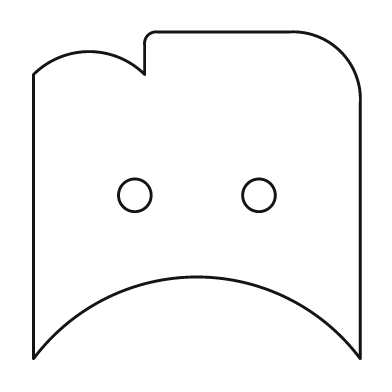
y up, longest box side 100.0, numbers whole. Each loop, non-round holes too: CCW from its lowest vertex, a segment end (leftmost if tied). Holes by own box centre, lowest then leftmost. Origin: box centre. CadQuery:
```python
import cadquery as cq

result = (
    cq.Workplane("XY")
    .moveTo(-50.0, -50.0)
    .threePointArc((0.0, -25.0), (50.0, -50.0))
    .lineTo(50.0, 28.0)
    .threePointArc((44.0, 44.0), (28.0, 50.0))
    .lineTo(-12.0, 50.0)
    .threePointArc((-15.0, 49.0), (-16.0, 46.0))
    .lineTo(-16.0, 37.0)
    .threePointArc((-33.0, 44.0), (-50.0, 37.0))
    .close()
    .moveTo(-19.0, 0.0)
    .circle(5.0)
    .moveTo(19.0, 0.0)
    .circle(5.0)
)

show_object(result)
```